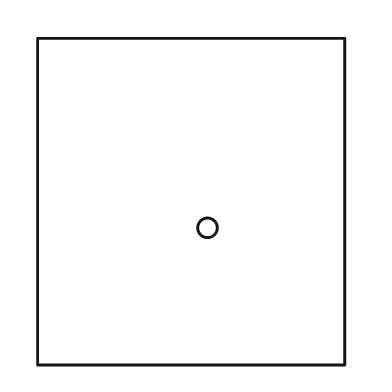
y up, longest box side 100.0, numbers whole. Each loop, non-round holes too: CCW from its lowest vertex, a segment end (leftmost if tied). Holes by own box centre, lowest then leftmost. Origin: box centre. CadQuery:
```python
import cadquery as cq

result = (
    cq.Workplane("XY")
    .moveTo(-47.0, -50.0)
    .lineTo(47.0, -50.0)
    .lineTo(47.0, 50.0)
    .lineTo(-47.0, 50.0)
    .close()
    .moveTo(5.0, -8.0)
    .circle(3.0)
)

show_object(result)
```